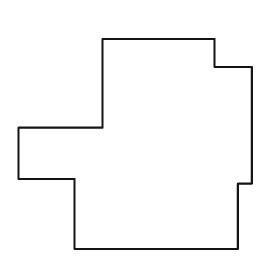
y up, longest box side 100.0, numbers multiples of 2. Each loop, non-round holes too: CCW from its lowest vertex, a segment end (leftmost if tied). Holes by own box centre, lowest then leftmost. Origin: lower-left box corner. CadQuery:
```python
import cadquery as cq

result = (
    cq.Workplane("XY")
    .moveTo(24.0, 0.0)
    .lineTo(94.0, 0.0)
    .lineTo(94.0, 28.0)
    .lineTo(100.0, 28.0)
    .lineTo(100.0, 78.0)
    .lineTo(84.0, 78.0)
    .lineTo(84.0, 90.0)
    .lineTo(36.0, 90.0)
    .lineTo(36.0, 52.0)
    .lineTo(0.0, 52.0)
    .lineTo(0.0, 30.0)
    .lineTo(24.0, 30.0)
    .close()
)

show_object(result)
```